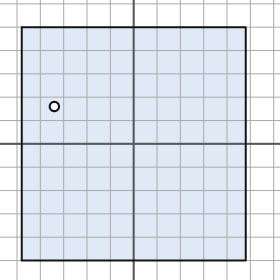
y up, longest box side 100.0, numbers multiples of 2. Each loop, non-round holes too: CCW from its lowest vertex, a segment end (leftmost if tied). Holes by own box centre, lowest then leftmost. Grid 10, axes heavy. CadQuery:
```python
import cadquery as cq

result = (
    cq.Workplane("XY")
    .moveTo(-48.0, -50.0)
    .lineTo(48.0, -50.0)
    .lineTo(48.0, 50.0)
    .lineTo(-48.0, 50.0)
    .close()
    .moveTo(-34.0, 16.0)
    .circle(2.0)
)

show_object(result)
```